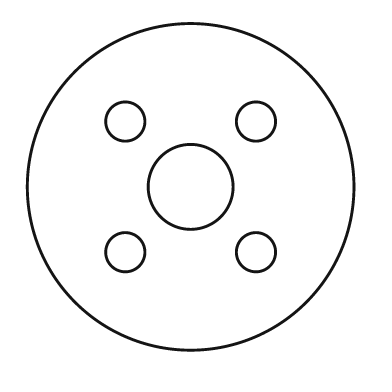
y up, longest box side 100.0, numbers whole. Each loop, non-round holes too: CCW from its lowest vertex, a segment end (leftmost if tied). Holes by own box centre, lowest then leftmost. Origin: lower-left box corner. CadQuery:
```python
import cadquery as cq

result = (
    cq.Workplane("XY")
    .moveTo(50.0, 50.0)
    .circle(50.0)
    .moveTo(30.0, 30.0)
    .circle(6.0)
    .moveTo(70.0, 30.0)
    .circle(6.0)
    .moveTo(50.0, 50.0)
    .circle(13.0)
    .moveTo(30.0, 70.0)
    .circle(6.0)
    .moveTo(70.0, 70.0)
    .circle(6.0)
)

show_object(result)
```